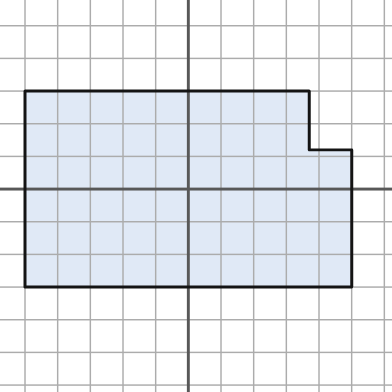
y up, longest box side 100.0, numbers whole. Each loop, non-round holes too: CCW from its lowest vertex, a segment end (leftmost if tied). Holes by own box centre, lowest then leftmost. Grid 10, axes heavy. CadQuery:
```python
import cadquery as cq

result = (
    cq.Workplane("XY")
    .moveTo(-50.0, -30.0)
    .lineTo(50.0, -30.0)
    .lineTo(50.0, 12.0)
    .lineTo(37.0, 12.0)
    .lineTo(37.0, 30.0)
    .lineTo(-50.0, 30.0)
    .close()
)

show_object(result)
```